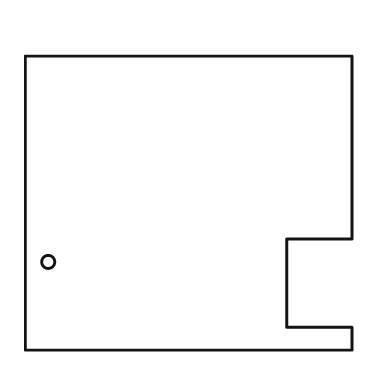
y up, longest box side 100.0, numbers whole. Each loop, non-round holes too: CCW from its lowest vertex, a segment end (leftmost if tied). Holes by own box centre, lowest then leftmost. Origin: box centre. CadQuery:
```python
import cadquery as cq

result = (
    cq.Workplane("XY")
    .moveTo(-50.0, -45.0)
    .lineTo(50.0, -45.0)
    .lineTo(50.0, -38.0)
    .lineTo(30.0, -38.0)
    .lineTo(30.0, -11.0)
    .lineTo(50.0, -11.0)
    .lineTo(50.0, 45.0)
    .lineTo(-50.0, 45.0)
    .close()
    .moveTo(-43.0, -18.0)
    .circle(2.0)
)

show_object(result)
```